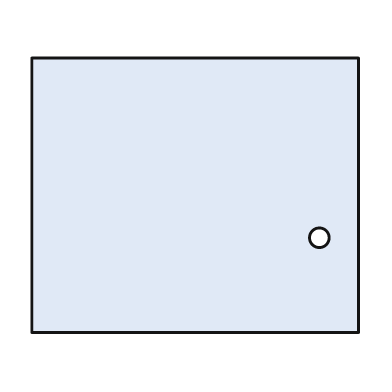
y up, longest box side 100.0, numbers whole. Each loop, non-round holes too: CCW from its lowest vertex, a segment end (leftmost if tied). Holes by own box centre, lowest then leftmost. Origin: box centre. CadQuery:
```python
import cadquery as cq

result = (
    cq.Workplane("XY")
    .moveTo(-50.0, -42.0)
    .lineTo(50.0, -42.0)
    .lineTo(50.0, 42.0)
    .lineTo(-50.0, 42.0)
    .close()
    .moveTo(38.0, -13.0)
    .circle(3.0)
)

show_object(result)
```